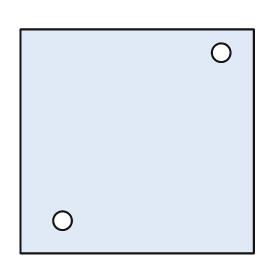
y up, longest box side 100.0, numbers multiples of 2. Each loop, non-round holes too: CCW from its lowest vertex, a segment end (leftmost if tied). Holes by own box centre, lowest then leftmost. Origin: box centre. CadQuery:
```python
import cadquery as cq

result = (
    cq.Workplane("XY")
    .moveTo(-50.0, -48.0)
    .lineTo(50.0, -48.0)
    .lineTo(50.0, 48.0)
    .lineTo(-50.0, 48.0)
    .close()
    .moveTo(-32.0, -34.0)
    .circle(4.0)
    .moveTo(36.0, 38.0)
    .circle(4.0)
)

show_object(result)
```